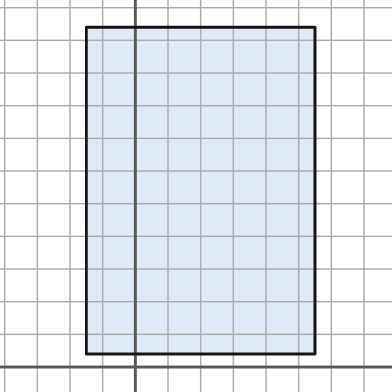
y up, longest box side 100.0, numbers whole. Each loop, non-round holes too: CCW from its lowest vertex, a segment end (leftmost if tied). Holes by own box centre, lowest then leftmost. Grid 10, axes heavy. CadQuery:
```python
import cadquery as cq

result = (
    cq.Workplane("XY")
    .moveTo(-15.0, 4.0)
    .lineTo(55.0, 4.0)
    .lineTo(55.0, 104.0)
    .lineTo(-15.0, 104.0)
    .close()
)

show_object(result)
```